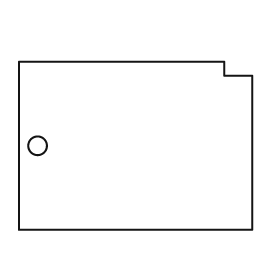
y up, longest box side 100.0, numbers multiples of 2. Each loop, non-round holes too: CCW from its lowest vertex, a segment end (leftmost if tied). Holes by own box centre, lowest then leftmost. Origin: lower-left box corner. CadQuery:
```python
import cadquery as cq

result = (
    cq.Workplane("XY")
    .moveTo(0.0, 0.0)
    .lineTo(100.0, 0.0)
    .lineTo(100.0, 66.0)
    .lineTo(88.0, 66.0)
    .lineTo(88.0, 72.0)
    .lineTo(0.0, 72.0)
    .close()
    .moveTo(8.0, 36.0)
    .circle(4.0)
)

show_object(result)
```